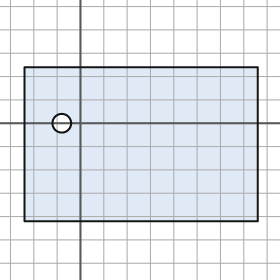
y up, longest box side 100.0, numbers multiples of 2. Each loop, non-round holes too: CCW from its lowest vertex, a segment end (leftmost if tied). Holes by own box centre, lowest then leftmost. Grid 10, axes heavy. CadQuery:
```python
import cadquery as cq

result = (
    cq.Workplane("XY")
    .moveTo(-24.0, -42.0)
    .lineTo(76.0, -42.0)
    .lineTo(76.0, 24.0)
    .lineTo(-24.0, 24.0)
    .close()
    .moveTo(-8.0, 0.0)
    .circle(4.0)
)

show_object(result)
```